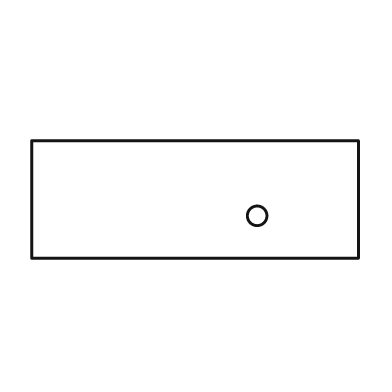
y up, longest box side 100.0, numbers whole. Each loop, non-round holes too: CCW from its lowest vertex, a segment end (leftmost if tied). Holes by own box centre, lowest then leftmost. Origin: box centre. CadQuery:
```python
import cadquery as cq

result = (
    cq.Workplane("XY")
    .moveTo(-50.0, -18.0)
    .lineTo(50.0, -18.0)
    .lineTo(50.0, 18.0)
    .lineTo(-50.0, 18.0)
    .close()
    .moveTo(19.0, -5.0)
    .circle(3.0)
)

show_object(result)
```